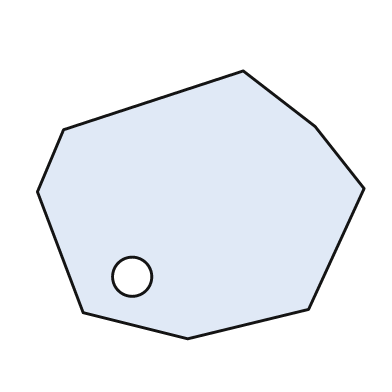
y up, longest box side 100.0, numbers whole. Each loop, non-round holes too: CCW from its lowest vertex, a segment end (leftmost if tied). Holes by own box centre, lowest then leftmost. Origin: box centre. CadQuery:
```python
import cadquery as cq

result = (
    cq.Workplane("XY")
    .moveTo(-4.0, -41.0)
    .lineTo(33.0, -32.0)
    .lineTo(50.0, 5.0)
    .lineTo(35.0, 24.0)
    .lineTo(13.0, 41.0)
    .lineTo(-42.0, 23.0)
    .lineTo(-50.0, 4.0)
    .lineTo(-36.0, -33.0)
    .close()
    .moveTo(-21.0, -22.0)
    .circle(6.0)
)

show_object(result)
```